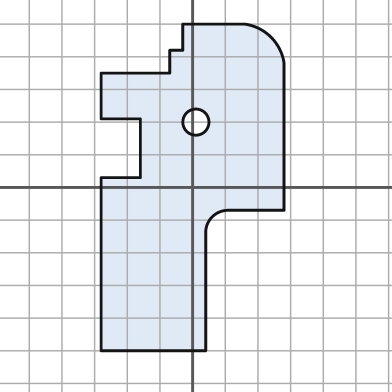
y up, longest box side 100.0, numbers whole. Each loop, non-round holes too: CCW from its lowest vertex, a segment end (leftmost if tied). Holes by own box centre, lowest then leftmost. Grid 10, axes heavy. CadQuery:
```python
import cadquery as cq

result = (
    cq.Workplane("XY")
    .moveTo(-28.0, -50.0)
    .lineTo(4.0, -50.0)
    .lineTo(4.0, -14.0)
    .threePointArc((6.0, -9.0), (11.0, -7.0))
    .lineTo(28.0, -7.0)
    .lineTo(28.0, 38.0)
    .threePointArc((24.0, 46.0), (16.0, 50.0))
    .lineTo(-3.0, 50.0)
    .lineTo(-3.0, 42.0)
    .lineTo(-7.0, 42.0)
    .lineTo(-7.0, 35.0)
    .lineTo(-28.0, 35.0)
    .lineTo(-28.0, 21.0)
    .lineTo(-16.0, 21.0)
    .lineTo(-16.0, 3.0)
    .lineTo(-28.0, 3.0)
    .close()
    .moveTo(1.0, 20.0)
    .circle(4.0)
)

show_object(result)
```